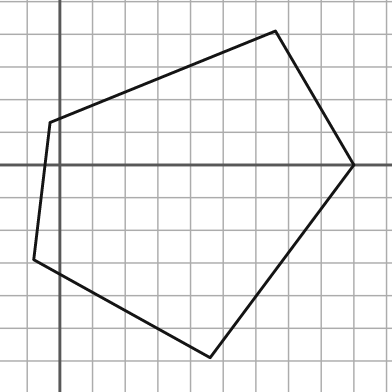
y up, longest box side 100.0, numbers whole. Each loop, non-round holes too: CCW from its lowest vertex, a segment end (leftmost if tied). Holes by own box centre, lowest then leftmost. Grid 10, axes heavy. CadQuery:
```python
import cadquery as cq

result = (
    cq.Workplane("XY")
    .moveTo(46.0, -59.0)
    .lineTo(90.0, 0.0)
    .lineTo(66.0, 41.0)
    .lineTo(-3.0, 13.0)
    .lineTo(-8.0, -29.0)
    .close()
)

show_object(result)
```